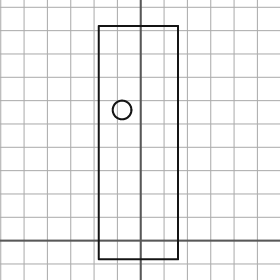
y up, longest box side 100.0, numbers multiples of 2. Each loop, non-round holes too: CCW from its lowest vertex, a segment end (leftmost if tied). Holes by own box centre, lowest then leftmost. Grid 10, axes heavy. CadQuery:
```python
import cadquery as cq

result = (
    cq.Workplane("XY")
    .moveTo(-18.0, -8.0)
    .lineTo(16.0, -8.0)
    .lineTo(16.0, 92.0)
    .lineTo(-18.0, 92.0)
    .close()
    .moveTo(-8.0, 56.0)
    .circle(4.0)
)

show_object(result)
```